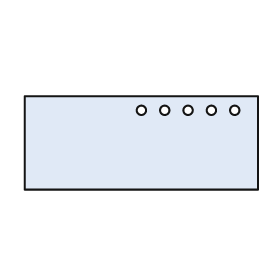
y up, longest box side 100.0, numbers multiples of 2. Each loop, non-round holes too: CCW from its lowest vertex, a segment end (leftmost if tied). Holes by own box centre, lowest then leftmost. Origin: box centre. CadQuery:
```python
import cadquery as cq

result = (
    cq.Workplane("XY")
    .moveTo(-50.0, -20.0)
    .lineTo(50.0, -20.0)
    .lineTo(50.0, 20.0)
    .lineTo(-50.0, 20.0)
    .close()
    .moveTo(0.0, 14.0)
    .circle(2.0)
    .moveTo(10.0, 14.0)
    .circle(2.0)
    .moveTo(20.0, 14.0)
    .circle(2.0)
    .moveTo(30.0, 14.0)
    .circle(2.0)
    .moveTo(40.0, 14.0)
    .circle(2.0)
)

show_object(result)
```